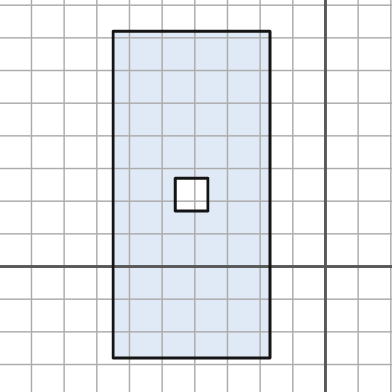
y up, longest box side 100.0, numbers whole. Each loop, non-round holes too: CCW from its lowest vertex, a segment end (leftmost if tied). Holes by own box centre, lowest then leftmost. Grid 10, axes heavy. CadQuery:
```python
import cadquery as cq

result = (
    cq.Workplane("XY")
    .moveTo(-65.0, -28.0)
    .lineTo(-17.0, -28.0)
    .lineTo(-17.0, 72.0)
    .lineTo(-65.0, 72.0)
    .close()
    .moveTo(-46.0, 17.0)
    .lineTo(-36.0, 17.0)
    .lineTo(-36.0, 27.0)
    .lineTo(-46.0, 27.0)
    .close()
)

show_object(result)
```